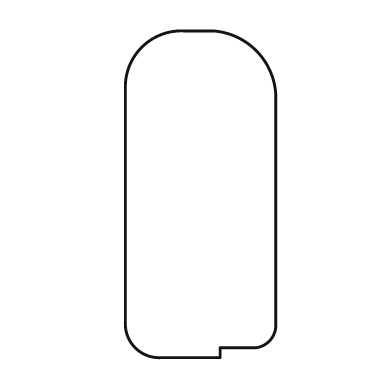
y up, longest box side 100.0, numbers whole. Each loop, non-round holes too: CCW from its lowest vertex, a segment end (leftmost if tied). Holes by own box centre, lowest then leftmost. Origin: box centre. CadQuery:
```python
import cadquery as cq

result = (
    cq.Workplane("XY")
    .moveTo(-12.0, -50.0)
    .lineTo(6.0, -50.0)
    .lineTo(6.0, -47.0)
    .lineTo(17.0, -47.0)
    .threePointArc((21.0, -45.0), (23.0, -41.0))
    .lineTo(23.0, 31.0)
    .threePointArc((17.0, 44.0), (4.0, 50.0))
    .lineTo(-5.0, 50.0)
    .threePointArc((-18.0, 45.0), (-23.0, 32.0))
    .lineTo(-23.0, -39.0)
    .threePointArc((-20.0, -47.0), (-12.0, -50.0))
    .close()
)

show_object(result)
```